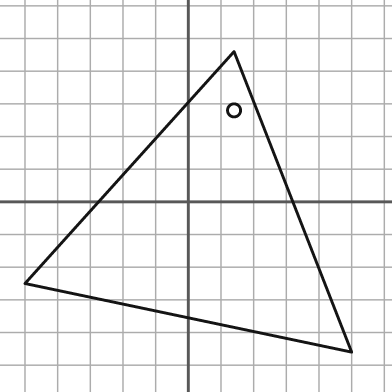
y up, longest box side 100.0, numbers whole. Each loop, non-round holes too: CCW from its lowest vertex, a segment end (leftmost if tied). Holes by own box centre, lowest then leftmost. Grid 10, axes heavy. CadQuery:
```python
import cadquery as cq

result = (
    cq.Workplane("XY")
    .moveTo(50.0, -46.0)
    .lineTo(14.0, 46.0)
    .lineTo(-50.0, -25.0)
    .close()
    .moveTo(14.0, 28.0)
    .circle(2.0)
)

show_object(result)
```